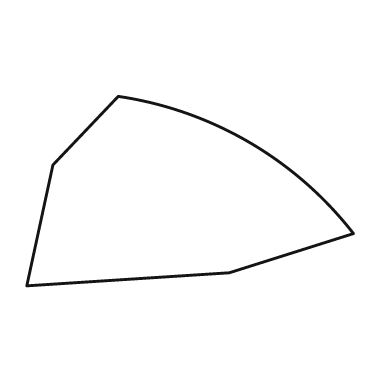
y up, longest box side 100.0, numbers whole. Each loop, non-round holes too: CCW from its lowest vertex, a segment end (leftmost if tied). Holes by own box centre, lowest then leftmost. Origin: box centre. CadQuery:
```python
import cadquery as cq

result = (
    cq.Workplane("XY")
    .moveTo(-50.0, -29.0)
    .lineTo(12.0, -25.0)
    .lineTo(50.0, -13.0)
    .threePointArc((18.0, 15.0), (-22.0, 29.0))
    .lineTo(-42.0, 8.0)
    .close()
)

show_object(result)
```